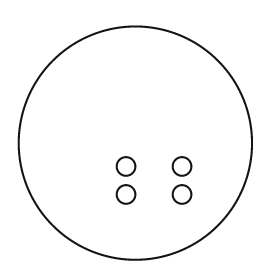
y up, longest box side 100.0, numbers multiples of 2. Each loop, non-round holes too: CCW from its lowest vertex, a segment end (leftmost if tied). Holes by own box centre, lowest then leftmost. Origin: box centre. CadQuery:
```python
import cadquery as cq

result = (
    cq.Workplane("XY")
    .moveTo(0.0, 0.0)
    .circle(50.0)
    .moveTo(-4.0, -22.0)
    .circle(4.0)
    .moveTo(20.0, -22.0)
    .circle(4.0)
    .moveTo(-4.0, -10.0)
    .circle(4.0)
    .moveTo(20.0, -10.0)
    .circle(4.0)
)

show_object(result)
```